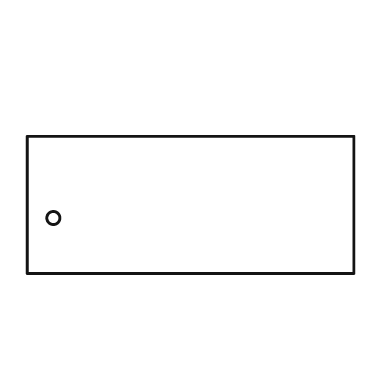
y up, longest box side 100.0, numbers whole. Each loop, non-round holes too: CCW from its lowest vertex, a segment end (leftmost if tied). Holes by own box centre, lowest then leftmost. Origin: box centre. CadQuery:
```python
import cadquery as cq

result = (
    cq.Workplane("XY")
    .moveTo(-50.0, -21.0)
    .lineTo(50.0, -21.0)
    .lineTo(50.0, 21.0)
    .lineTo(-50.0, 21.0)
    .close()
    .moveTo(-42.0, -4.0)
    .circle(2.0)
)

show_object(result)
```